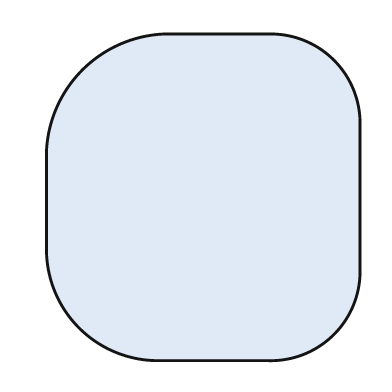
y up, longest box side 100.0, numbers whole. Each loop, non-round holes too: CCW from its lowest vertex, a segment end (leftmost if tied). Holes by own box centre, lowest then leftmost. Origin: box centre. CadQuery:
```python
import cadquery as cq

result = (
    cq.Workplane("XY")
    .moveTo(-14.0, -50.0)
    .lineTo(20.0, -50.0)
    .threePointArc((40.0, -42.0), (48.0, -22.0))
    .lineTo(48.0, 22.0)
    .threePointArc((40.0, 42.0), (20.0, 50.0))
    .lineTo(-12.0, 50.0)
    .threePointArc((-37.0, 39.0), (-48.0, 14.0))
    .lineTo(-48.0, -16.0)
    .threePointArc((-38.0, -40.0), (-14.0, -50.0))
    .close()
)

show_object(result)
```